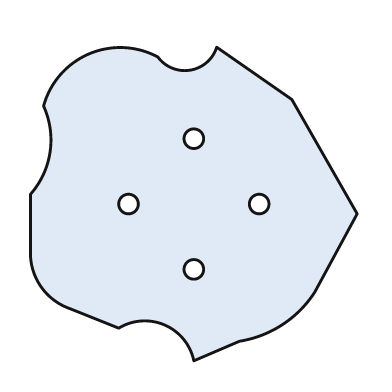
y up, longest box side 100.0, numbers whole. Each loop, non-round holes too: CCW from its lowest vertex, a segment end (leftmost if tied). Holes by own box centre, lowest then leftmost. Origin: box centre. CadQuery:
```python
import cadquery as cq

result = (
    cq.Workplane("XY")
    .moveTo(0.0, -48.0)
    .lineTo(14.0, -42.0)
    .threePointArc((27.0, -37.0), (37.0, -27.0))
    .lineTo(50.0, -3.0)
    .lineTo(30.0, 32.0)
    .lineTo(7.0, 48.0)
    .threePointArc((-1.0, 41.0), (-11.0, 45.0))
    .threePointArc((-32.0, 46.0), (-46.0, 30.0))
    .threePointArc((-44.0, 16.0), (-50.0, 3.0))
    .lineTo(-50.0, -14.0)
    .threePointArc((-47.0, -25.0), (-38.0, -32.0))
    .lineTo(-23.0, -38.0)
    .threePointArc((-9.0, -37.0), (0.0, -48.0))
    .close()
    .moveTo(0.0, -20.0)
    .circle(3.0)
    .moveTo(-20.0, 0.0)
    .circle(3.0)
    .moveTo(20.0, 0.0)
    .circle(3.0)
    .moveTo(0.0, 20.0)
    .circle(3.0)
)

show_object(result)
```